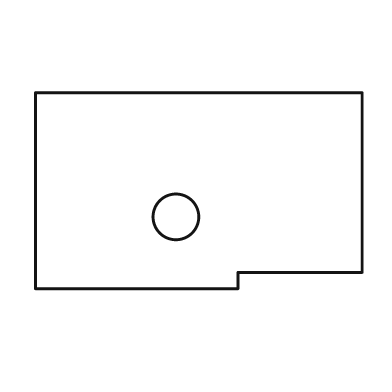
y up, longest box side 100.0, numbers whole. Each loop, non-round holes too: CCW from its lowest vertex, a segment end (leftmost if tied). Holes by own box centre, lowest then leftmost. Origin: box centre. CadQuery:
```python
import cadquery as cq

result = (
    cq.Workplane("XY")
    .moveTo(-50.0, -30.0)
    .lineTo(12.0, -30.0)
    .lineTo(12.0, -25.0)
    .lineTo(50.0, -25.0)
    .lineTo(50.0, 30.0)
    .lineTo(-50.0, 30.0)
    .close()
    .moveTo(-7.0, -8.0)
    .circle(7.0)
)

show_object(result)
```